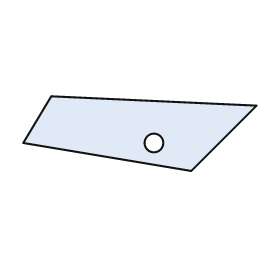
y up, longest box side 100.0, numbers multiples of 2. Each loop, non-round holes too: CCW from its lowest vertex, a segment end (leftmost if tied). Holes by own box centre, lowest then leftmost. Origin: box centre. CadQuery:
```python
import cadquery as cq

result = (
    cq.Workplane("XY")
    .moveTo(22.0, -16.0)
    .lineTo(50.0, 12.0)
    .lineTo(-38.0, 16.0)
    .lineTo(-50.0, -4.0)
    .close()
    .moveTo(6.0, -4.0)
    .circle(4.0)
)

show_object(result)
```